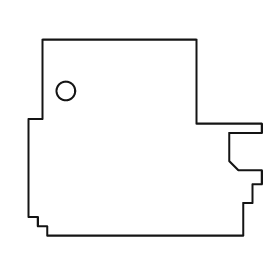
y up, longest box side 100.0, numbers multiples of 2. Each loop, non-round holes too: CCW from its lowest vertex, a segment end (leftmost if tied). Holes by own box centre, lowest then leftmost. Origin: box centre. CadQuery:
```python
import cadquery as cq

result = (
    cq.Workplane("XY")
    .moveTo(-42.0, -42.0)
    .lineTo(42.0, -42.0)
    .lineTo(42.0, -28.0)
    .lineTo(46.0, -28.0)
    .lineTo(46.0, -20.0)
    .lineTo(50.0, -20.0)
    .lineTo(50.0, -14.0)
    .lineTo(40.0, -14.0)
    .lineTo(36.0, -10.0)
    .lineTo(36.0, 2.0)
    .lineTo(50.0, 2.0)
    .lineTo(50.0, 6.0)
    .lineTo(22.0, 6.0)
    .lineTo(22.0, 42.0)
    .lineTo(-44.0, 42.0)
    .lineTo(-44.0, 8.0)
    .lineTo(-50.0, 8.0)
    .lineTo(-50.0, -34.0)
    .lineTo(-46.0, -34.0)
    .lineTo(-46.0, -38.0)
    .lineTo(-42.0, -38.0)
    .close()
    .moveTo(-34.0, 20.0)
    .circle(4.0)
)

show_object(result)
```